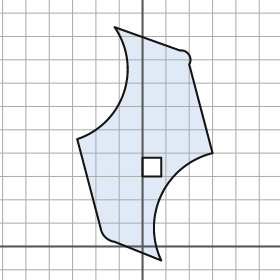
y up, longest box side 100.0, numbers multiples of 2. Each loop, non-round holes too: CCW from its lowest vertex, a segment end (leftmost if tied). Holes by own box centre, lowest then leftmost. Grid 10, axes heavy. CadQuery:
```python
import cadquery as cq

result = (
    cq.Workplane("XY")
    .moveTo(8.0, -6.0)
    .threePointArc((8.0, 22.0), (30.0, 40.0))
    .lineTo(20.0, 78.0)
    .threePointArc((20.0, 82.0), (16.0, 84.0))
    .lineTo(-12.0, 94.0)
    .threePointArc((-8.0, 66.0), (-28.0, 46.0))
    .lineTo(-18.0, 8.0)
    .threePointArc((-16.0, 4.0), (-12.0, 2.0))
    .close()
    .moveTo(0.0, 30.0)
    .lineTo(8.0, 30.0)
    .lineTo(8.0, 38.0)
    .lineTo(0.0, 38.0)
    .close()
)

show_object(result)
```